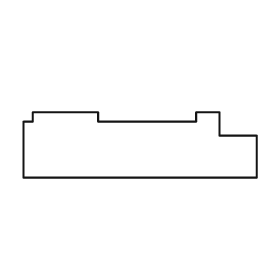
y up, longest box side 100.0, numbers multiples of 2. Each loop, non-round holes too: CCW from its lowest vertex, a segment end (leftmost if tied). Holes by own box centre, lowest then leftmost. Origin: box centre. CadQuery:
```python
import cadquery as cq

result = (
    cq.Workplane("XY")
    .moveTo(-50.0, -14.0)
    .lineTo(50.0, -14.0)
    .lineTo(50.0, 4.0)
    .lineTo(34.0, 4.0)
    .lineTo(34.0, 14.0)
    .lineTo(24.0, 14.0)
    .lineTo(24.0, 10.0)
    .lineTo(-18.0, 10.0)
    .lineTo(-18.0, 14.0)
    .lineTo(-46.0, 14.0)
    .lineTo(-46.0, 10.0)
    .lineTo(-50.0, 10.0)
    .close()
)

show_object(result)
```